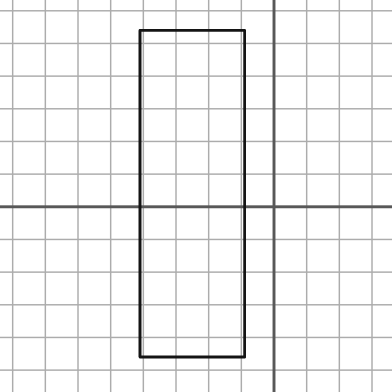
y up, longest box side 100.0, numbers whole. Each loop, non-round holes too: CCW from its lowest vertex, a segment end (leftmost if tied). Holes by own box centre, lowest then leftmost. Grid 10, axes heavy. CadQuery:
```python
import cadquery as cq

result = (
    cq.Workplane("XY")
    .moveTo(-41.0, -46.0)
    .lineTo(-9.0, -46.0)
    .lineTo(-9.0, 54.0)
    .lineTo(-41.0, 54.0)
    .close()
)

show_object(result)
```